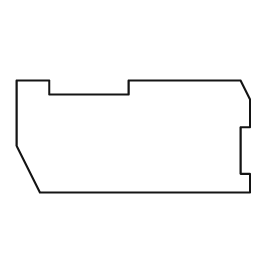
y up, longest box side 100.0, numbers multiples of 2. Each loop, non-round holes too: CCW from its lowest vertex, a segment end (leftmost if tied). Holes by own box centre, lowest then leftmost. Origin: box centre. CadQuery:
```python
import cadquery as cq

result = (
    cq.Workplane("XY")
    .moveTo(-40.0, -24.0)
    .lineTo(50.0, -24.0)
    .lineTo(50.0, -16.0)
    .lineTo(46.0, -16.0)
    .lineTo(46.0, 4.0)
    .lineTo(50.0, 4.0)
    .lineTo(50.0, 16.0)
    .lineTo(46.0, 24.0)
    .lineTo(-2.0, 24.0)
    .lineTo(-2.0, 18.0)
    .lineTo(-36.0, 18.0)
    .lineTo(-36.0, 24.0)
    .lineTo(-50.0, 24.0)
    .lineTo(-50.0, -4.0)
    .close()
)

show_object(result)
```